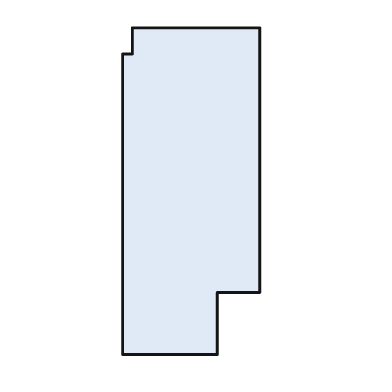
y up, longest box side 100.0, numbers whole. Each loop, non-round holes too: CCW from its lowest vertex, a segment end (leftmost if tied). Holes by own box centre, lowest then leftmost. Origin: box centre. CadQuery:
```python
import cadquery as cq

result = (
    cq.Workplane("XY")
    .moveTo(-21.0, -50.0)
    .lineTo(8.0, -50.0)
    .lineTo(8.0, -31.0)
    .lineTo(21.0, -31.0)
    .lineTo(21.0, 50.0)
    .lineTo(-18.0, 50.0)
    .lineTo(-18.0, 42.0)
    .lineTo(-21.0, 42.0)
    .close()
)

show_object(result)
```